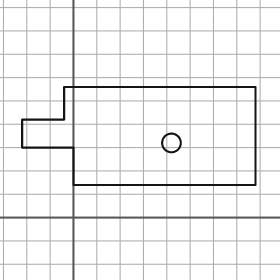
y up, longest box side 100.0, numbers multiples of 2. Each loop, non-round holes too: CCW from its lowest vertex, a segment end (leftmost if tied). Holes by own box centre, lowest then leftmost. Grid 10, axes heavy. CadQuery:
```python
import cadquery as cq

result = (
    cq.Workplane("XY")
    .moveTo(0.0, 14.0)
    .lineTo(78.0, 14.0)
    .lineTo(78.0, 56.0)
    .lineTo(-4.0, 56.0)
    .lineTo(-4.0, 42.0)
    .lineTo(-22.0, 42.0)
    .lineTo(-22.0, 30.0)
    .lineTo(0.0, 30.0)
    .close()
    .moveTo(42.0, 32.0)
    .circle(4.0)
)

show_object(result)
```